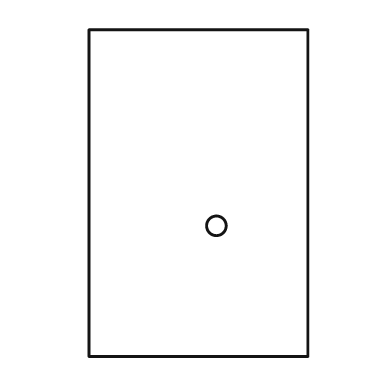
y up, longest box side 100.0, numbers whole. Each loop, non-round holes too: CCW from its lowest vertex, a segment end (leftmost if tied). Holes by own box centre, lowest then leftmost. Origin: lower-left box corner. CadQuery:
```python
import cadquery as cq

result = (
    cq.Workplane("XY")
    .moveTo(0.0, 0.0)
    .lineTo(67.0, 0.0)
    .lineTo(67.0, 100.0)
    .lineTo(0.0, 100.0)
    .close()
    .moveTo(39.0, 40.0)
    .circle(3.0)
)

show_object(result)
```